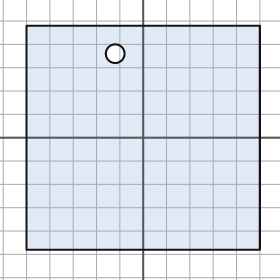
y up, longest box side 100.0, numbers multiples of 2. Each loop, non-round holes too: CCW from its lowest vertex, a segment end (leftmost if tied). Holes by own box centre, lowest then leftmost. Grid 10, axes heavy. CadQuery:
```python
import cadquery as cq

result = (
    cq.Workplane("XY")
    .moveTo(-50.0, -48.0)
    .lineTo(50.0, -48.0)
    .lineTo(50.0, 48.0)
    .lineTo(-50.0, 48.0)
    .close()
    .moveTo(-12.0, 36.0)
    .circle(4.0)
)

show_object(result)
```